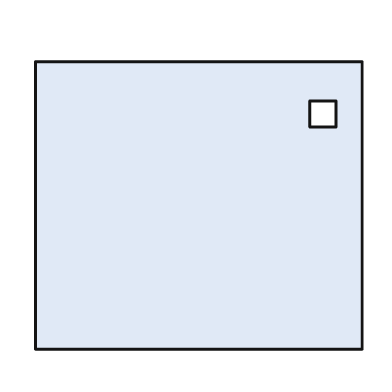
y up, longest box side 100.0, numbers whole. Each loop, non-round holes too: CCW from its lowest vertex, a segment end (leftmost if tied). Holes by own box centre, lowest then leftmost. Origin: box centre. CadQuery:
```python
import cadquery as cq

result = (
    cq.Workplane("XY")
    .moveTo(-50.0, -44.0)
    .lineTo(50.0, -44.0)
    .lineTo(50.0, 44.0)
    .lineTo(-50.0, 44.0)
    .close()
    .moveTo(34.0, 24.0)
    .lineTo(42.0, 24.0)
    .lineTo(42.0, 32.0)
    .lineTo(34.0, 32.0)
    .close()
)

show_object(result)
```